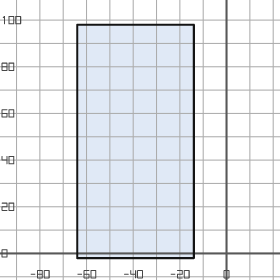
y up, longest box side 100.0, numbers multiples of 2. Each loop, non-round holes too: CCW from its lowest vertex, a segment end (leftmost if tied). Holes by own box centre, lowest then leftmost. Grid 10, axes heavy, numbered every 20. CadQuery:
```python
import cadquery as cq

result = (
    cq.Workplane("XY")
    .moveTo(-64.0, -2.0)
    .lineTo(-14.0, -2.0)
    .lineTo(-14.0, 98.0)
    .lineTo(-64.0, 98.0)
    .close()
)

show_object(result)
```